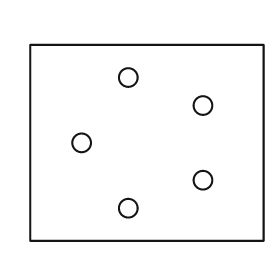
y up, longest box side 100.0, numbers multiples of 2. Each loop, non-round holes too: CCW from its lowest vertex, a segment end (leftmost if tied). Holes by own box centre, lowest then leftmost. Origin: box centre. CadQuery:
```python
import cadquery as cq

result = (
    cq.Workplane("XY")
    .moveTo(-50.0, -42.0)
    .lineTo(50.0, -42.0)
    .lineTo(50.0, 42.0)
    .lineTo(-50.0, 42.0)
    .close()
    .moveTo(-8.0, -28.0)
    .circle(4.0)
    .moveTo(24.0, -16.0)
    .circle(4.0)
    .moveTo(-28.0, 0.0)
    .circle(4.0)
    .moveTo(24.0, 16.0)
    .circle(4.0)
    .moveTo(-8.0, 28.0)
    .circle(4.0)
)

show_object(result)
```